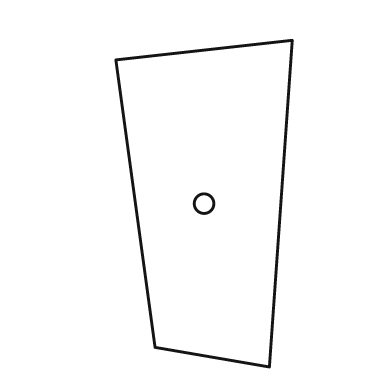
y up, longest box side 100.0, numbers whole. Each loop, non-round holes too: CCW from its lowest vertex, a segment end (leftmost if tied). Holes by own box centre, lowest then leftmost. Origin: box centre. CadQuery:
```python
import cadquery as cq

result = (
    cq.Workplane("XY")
    .moveTo(20.0, -50.0)
    .lineTo(27.0, 50.0)
    .lineTo(-27.0, 44.0)
    .lineTo(-15.0, -44.0)
    .close()
    .moveTo(0.0, 0.0)
    .circle(3.0)
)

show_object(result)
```